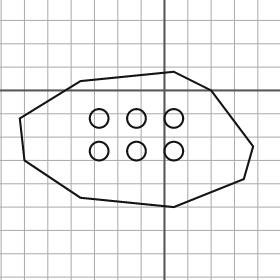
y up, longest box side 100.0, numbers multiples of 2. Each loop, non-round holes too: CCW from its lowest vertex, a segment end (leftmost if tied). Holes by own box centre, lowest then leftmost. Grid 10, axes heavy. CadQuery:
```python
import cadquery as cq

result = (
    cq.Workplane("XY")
    .moveTo(4.0, -50.0)
    .lineTo(34.0, -38.0)
    .lineTo(38.0, -24.0)
    .lineTo(20.0, 0.0)
    .lineTo(4.0, 8.0)
    .lineTo(-36.0, 4.0)
    .lineTo(-62.0, -12.0)
    .lineTo(-60.0, -30.0)
    .lineTo(-36.0, -46.0)
    .close()
    .moveTo(-28.0, -26.0)
    .circle(4.0)
    .moveTo(-12.0, -26.0)
    .circle(4.0)
    .moveTo(4.0, -26.0)
    .circle(4.0)
    .moveTo(-28.0, -12.0)
    .circle(4.0)
    .moveTo(-12.0, -12.0)
    .circle(4.0)
    .moveTo(4.0, -12.0)
    .circle(4.0)
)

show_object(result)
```